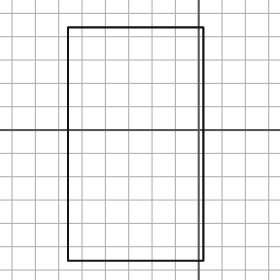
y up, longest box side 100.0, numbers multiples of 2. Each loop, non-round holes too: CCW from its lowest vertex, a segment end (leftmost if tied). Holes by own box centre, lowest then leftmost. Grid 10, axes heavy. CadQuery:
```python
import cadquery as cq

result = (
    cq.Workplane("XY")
    .moveTo(-56.0, -56.0)
    .lineTo(2.0, -56.0)
    .lineTo(2.0, 44.0)
    .lineTo(-56.0, 44.0)
    .close()
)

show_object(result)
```